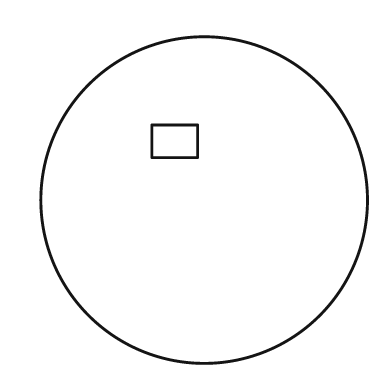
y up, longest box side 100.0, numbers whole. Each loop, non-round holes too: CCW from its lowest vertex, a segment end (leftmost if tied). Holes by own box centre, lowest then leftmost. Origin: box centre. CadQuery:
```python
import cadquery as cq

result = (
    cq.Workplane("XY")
    .moveTo(0.0, 0.0)
    .circle(50.0)
    .moveTo(-16.0, 13.0)
    .lineTo(-2.0, 13.0)
    .lineTo(-2.0, 23.0)
    .lineTo(-16.0, 23.0)
    .close()
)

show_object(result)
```